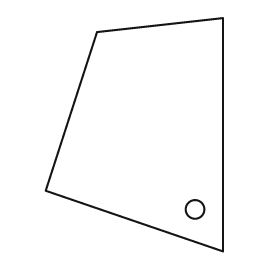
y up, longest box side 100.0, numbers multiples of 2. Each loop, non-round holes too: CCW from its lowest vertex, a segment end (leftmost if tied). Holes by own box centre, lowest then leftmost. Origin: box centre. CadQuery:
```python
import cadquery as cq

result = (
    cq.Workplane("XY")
    .moveTo(38.0, -50.0)
    .lineTo(38.0, 50.0)
    .lineTo(-16.0, 44.0)
    .lineTo(-38.0, -24.0)
    .close()
    .moveTo(26.0, -32.0)
    .circle(4.0)
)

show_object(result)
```